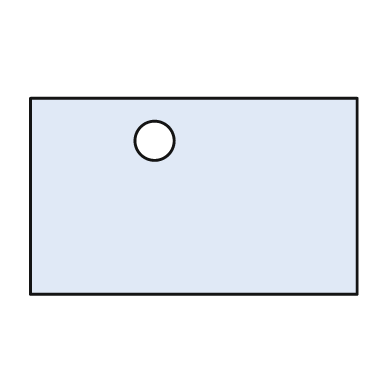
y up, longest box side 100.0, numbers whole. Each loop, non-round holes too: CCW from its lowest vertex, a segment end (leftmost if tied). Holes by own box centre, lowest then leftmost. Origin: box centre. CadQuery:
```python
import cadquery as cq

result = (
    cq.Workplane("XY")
    .moveTo(-50.0, -30.0)
    .lineTo(50.0, -30.0)
    .lineTo(50.0, 30.0)
    .lineTo(-50.0, 30.0)
    .close()
    .moveTo(-12.0, 17.0)
    .circle(6.0)
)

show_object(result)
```